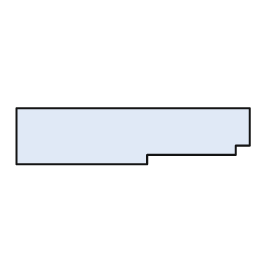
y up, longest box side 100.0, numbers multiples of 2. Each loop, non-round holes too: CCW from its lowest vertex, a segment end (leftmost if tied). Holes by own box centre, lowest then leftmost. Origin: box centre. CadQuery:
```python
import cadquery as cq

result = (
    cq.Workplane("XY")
    .moveTo(-50.0, -12.0)
    .lineTo(6.0, -12.0)
    .lineTo(6.0, -8.0)
    .lineTo(44.0, -8.0)
    .lineTo(44.0, -4.0)
    .lineTo(50.0, -4.0)
    .lineTo(50.0, 12.0)
    .lineTo(-50.0, 12.0)
    .close()
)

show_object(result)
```